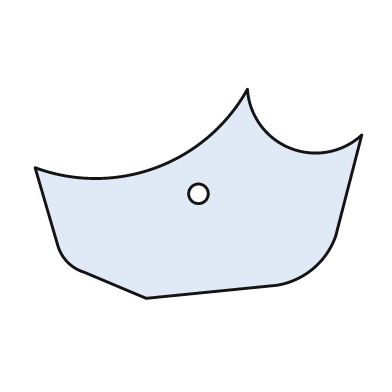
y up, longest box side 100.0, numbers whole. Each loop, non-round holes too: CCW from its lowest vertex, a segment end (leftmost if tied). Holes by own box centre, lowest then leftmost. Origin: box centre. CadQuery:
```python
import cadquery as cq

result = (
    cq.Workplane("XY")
    .moveTo(-16.0, -32.0)
    .lineTo(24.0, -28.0)
    .threePointArc((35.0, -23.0), (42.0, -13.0))
    .lineTo(50.0, 18.0)
    .threePointArc((28.0, 14.0), (15.0, 32.0))
    .threePointArc((-13.0, 8.0), (-50.0, 8.0))
    .lineTo(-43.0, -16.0)
    .threePointArc((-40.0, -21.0), (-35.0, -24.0))
    .close()
    .moveTo(0.0, 0.0)
    .circle(3.0)
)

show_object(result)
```